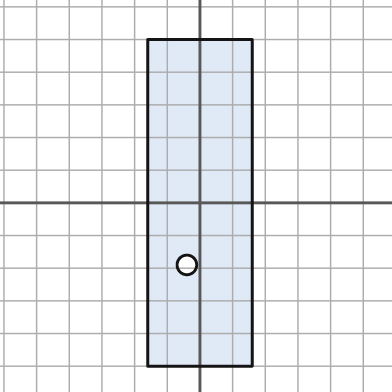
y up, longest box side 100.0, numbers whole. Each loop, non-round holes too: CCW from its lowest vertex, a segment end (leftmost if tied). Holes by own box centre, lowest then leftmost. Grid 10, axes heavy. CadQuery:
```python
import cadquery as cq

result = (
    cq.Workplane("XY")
    .moveTo(-16.0, -50.0)
    .lineTo(16.0, -50.0)
    .lineTo(16.0, 50.0)
    .lineTo(-16.0, 50.0)
    .close()
    .moveTo(-4.0, -19.0)
    .circle(3.0)
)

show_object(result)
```